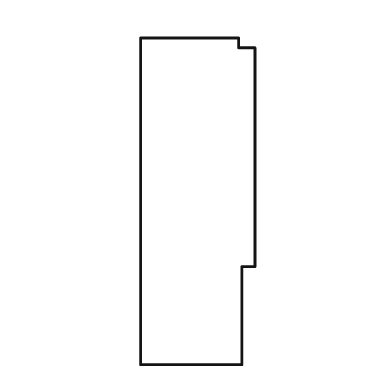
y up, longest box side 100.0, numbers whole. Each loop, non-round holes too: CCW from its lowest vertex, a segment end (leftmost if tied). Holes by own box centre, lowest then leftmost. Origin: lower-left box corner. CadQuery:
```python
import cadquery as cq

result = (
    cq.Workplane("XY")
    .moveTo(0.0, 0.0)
    .lineTo(31.0, 0.0)
    .lineTo(31.0, 30.0)
    .lineTo(35.0, 30.0)
    .lineTo(35.0, 97.0)
    .lineTo(30.0, 97.0)
    .lineTo(30.0, 100.0)
    .lineTo(0.0, 100.0)
    .close()
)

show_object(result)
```